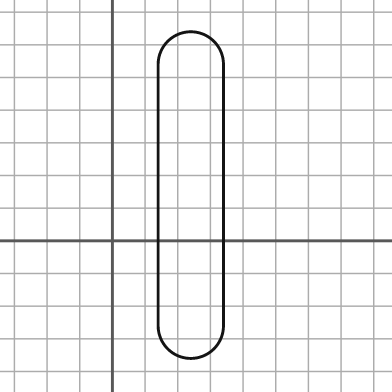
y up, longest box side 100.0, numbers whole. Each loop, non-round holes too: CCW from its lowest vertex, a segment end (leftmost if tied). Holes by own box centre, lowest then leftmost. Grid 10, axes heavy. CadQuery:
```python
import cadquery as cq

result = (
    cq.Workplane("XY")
    .moveTo(14.0, -26.0)
    .threePointArc((24.0, -36.0), (34.0, -26.0))
    .lineTo(34.0, 54.0)
    .threePointArc((24.0, 64.0), (14.0, 54.0))
    .close()
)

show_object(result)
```